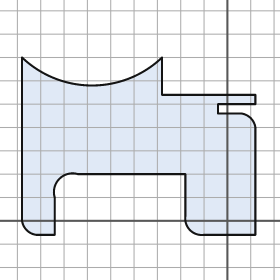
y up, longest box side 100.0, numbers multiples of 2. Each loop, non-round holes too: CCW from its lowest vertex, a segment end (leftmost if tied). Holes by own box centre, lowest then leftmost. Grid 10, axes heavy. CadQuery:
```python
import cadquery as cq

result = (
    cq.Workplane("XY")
    .moveTo(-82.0, -6.0)
    .lineTo(-74.0, -6.0)
    .lineTo(-74.0, 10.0)
    .threePointArc((-72.0, 18.0), (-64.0, 20.0))
    .lineTo(-18.0, 20.0)
    .lineTo(-18.0, 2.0)
    .threePointArc((-16.0, -4.0), (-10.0, -6.0))
    .lineTo(12.0, -6.0)
    .lineTo(12.0, 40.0)
    .threePointArc((10.0, 44.0), (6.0, 46.0))
    .lineTo(-4.0, 46.0)
    .lineTo(-4.0, 50.0)
    .lineTo(12.0, 50.0)
    .lineTo(12.0, 54.0)
    .lineTo(-28.0, 54.0)
    .lineTo(-28.0, 70.0)
    .threePointArc((-58.0, 58.0), (-88.0, 70.0))
    .lineTo(-88.0, 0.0)
    .threePointArc((-86.0, -4.0), (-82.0, -6.0))
    .close()
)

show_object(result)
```